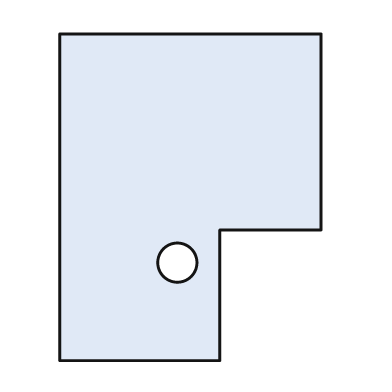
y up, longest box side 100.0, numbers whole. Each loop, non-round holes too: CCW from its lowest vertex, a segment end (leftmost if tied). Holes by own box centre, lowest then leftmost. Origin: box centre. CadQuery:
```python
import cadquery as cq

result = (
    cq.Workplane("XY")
    .moveTo(-40.0, -50.0)
    .lineTo(9.0, -50.0)
    .lineTo(9.0, -10.0)
    .lineTo(40.0, -10.0)
    .lineTo(40.0, 50.0)
    .lineTo(-40.0, 50.0)
    .close()
    .moveTo(-4.0, -20.0)
    .circle(6.0)
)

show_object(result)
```